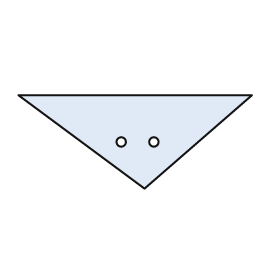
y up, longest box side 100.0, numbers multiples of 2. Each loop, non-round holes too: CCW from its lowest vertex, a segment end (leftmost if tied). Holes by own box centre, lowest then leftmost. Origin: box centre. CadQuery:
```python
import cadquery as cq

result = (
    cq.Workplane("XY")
    .moveTo(4.0, -20.0)
    .lineTo(50.0, 20.0)
    .lineTo(-50.0, 20.0)
    .close()
    .moveTo(-6.0, 0.0)
    .circle(2.0)
    .moveTo(8.0, 0.0)
    .circle(2.0)
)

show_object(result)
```